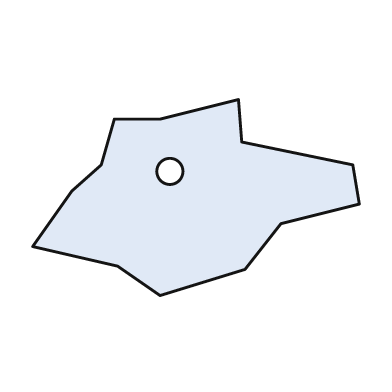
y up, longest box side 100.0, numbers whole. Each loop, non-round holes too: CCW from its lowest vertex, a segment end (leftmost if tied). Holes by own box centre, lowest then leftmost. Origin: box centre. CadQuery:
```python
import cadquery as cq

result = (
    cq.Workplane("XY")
    .moveTo(-11.0, -30.0)
    .lineTo(15.0, -22.0)
    .lineTo(26.0, -8.0)
    .lineTo(50.0, -2.0)
    .lineTo(48.0, 10.0)
    .lineTo(14.0, 17.0)
    .lineTo(13.0, 30.0)
    .lineTo(-11.0, 24.0)
    .lineTo(-25.0, 24.0)
    .lineTo(-29.0, 10.0)
    .lineTo(-38.0, 2.0)
    .lineTo(-50.0, -15.0)
    .lineTo(-24.0, -21.0)
    .close()
    .moveTo(-8.0, 8.0)
    .circle(4.0)
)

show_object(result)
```